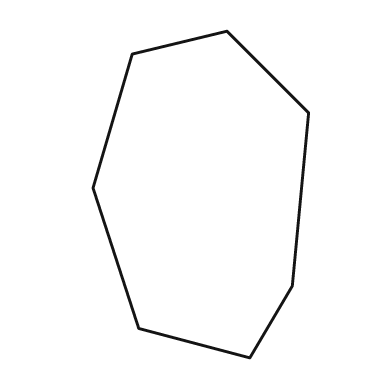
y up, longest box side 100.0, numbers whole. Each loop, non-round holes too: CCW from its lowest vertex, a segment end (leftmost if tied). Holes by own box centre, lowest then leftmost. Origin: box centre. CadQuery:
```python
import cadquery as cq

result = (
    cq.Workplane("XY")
    .moveTo(15.0, -50.0)
    .lineTo(28.0, -28.0)
    .lineTo(33.0, 25.0)
    .lineTo(8.0, 50.0)
    .lineTo(-21.0, 43.0)
    .lineTo(-33.0, 2.0)
    .lineTo(-19.0, -41.0)
    .close()
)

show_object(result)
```